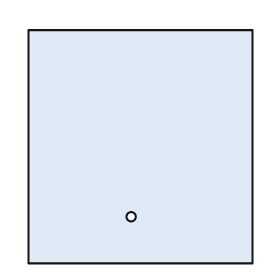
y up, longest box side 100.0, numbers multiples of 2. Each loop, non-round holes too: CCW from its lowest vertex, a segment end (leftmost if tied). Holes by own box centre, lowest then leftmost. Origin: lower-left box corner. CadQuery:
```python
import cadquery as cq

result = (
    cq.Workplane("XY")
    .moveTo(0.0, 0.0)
    .lineTo(96.0, 0.0)
    .lineTo(96.0, 100.0)
    .lineTo(0.0, 100.0)
    .close()
    .moveTo(44.0, 20.0)
    .circle(2.0)
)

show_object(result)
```